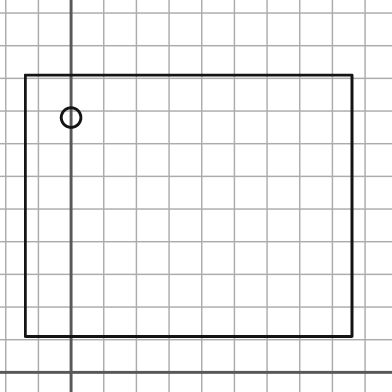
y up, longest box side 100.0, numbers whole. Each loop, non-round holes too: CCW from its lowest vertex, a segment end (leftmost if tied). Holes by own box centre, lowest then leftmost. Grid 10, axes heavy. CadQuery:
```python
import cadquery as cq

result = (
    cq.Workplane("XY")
    .moveTo(-14.0, 11.0)
    .lineTo(86.0, 11.0)
    .lineTo(86.0, 91.0)
    .lineTo(-14.0, 91.0)
    .close()
    .moveTo(0.0, 78.0)
    .circle(3.0)
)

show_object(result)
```